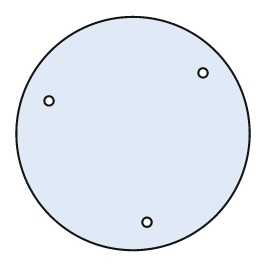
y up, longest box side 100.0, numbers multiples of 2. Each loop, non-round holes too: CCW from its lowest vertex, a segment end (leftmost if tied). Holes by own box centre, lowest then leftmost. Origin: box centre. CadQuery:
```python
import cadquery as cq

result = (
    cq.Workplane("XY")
    .moveTo(0.0, 0.0)
    .circle(50.0)
    .moveTo(6.0, -38.0)
    .circle(2.0)
    .moveTo(-36.0, 14.0)
    .circle(2.0)
    .moveTo(30.0, 26.0)
    .circle(2.0)
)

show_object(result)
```